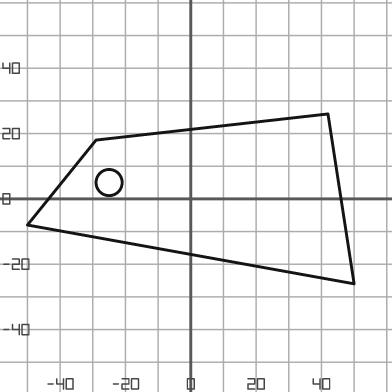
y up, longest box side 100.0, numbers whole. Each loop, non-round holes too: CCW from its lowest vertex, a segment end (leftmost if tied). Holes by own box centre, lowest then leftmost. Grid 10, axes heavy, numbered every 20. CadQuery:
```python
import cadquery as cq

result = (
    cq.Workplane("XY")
    .moveTo(50.0, -26.0)
    .lineTo(42.0, 26.0)
    .lineTo(-29.0, 18.0)
    .lineTo(-50.0, -8.0)
    .close()
    .moveTo(-25.0, 5.0)
    .circle(4.0)
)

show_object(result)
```